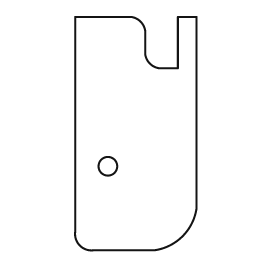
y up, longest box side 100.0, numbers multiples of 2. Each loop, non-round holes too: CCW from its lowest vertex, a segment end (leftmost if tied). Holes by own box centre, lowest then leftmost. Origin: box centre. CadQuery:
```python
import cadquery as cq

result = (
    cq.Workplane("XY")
    .moveTo(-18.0, -50.0)
    .lineTo(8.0, -50.0)
    .threePointArc((20.0, -44.0), (26.0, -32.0))
    .lineTo(26.0, 50.0)
    .lineTo(18.0, 50.0)
    .lineTo(18.0, 28.0)
    .lineTo(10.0, 28.0)
    .threePointArc((6.0, 30.0), (4.0, 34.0))
    .lineTo(4.0, 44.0)
    .threePointArc((2.0, 48.0), (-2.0, 50.0))
    .lineTo(-26.0, 50.0)
    .lineTo(-26.0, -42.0)
    .threePointArc((-24.0, -48.0), (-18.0, -50.0))
    .close()
    .moveTo(-12.0, -14.0)
    .circle(4.0)
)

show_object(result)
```